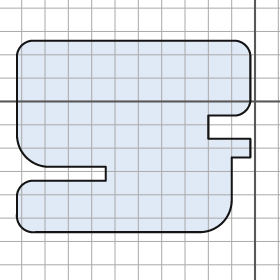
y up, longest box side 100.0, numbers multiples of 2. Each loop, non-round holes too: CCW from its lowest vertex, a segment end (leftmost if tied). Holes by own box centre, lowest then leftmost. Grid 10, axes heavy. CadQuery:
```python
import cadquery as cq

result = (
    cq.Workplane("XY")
    .moveTo(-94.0, -56.0)
    .lineTo(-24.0, -56.0)
    .threePointArc((-14.0, -52.0), (-10.0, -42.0))
    .lineTo(-10.0, -24.0)
    .lineTo(-2.0, -24.0)
    .lineTo(-2.0, -16.0)
    .lineTo(-20.0, -16.0)
    .lineTo(-20.0, -6.0)
    .lineTo(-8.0, -6.0)
    .threePointArc((-4.0, -4.0), (-2.0, 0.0))
    .lineTo(-2.0, 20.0)
    .threePointArc((-4.0, 24.0), (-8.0, 26.0))
    .lineTo(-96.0, 26.0)
    .threePointArc((-100.0, 24.0), (-102.0, 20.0))
    .lineTo(-102.0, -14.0)
    .threePointArc((-98.0, -24.0), (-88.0, -28.0))
    .lineTo(-64.0, -28.0)
    .lineTo(-64.0, -34.0)
    .lineTo(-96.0, -34.0)
    .threePointArc((-100.0, -36.0), (-102.0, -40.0))
    .lineTo(-102.0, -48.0)
    .threePointArc((-100.0, -54.0), (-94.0, -56.0))
    .close()
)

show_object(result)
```